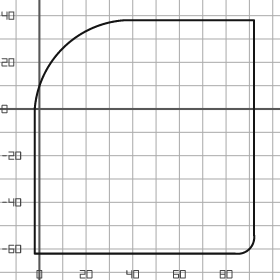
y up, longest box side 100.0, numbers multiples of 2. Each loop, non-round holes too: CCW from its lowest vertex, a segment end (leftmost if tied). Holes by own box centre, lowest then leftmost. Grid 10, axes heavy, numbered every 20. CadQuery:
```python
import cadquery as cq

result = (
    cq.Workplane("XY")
    .moveTo(-2.0, -62.0)
    .lineTo(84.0, -62.0)
    .threePointArc((90.0, -60.0), (92.0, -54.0))
    .lineTo(92.0, 38.0)
    .lineTo(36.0, 38.0)
    .threePointArc((10.0, 26.0), (-2.0, 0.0))
    .close()
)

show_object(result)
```